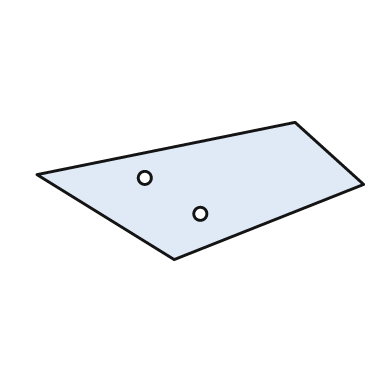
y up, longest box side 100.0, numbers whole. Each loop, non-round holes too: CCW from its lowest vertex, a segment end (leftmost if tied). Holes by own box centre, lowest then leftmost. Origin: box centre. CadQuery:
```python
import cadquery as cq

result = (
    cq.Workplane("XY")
    .moveTo(-8.0, -21.0)
    .lineTo(50.0, 2.0)
    .lineTo(29.0, 21.0)
    .lineTo(-50.0, 5.0)
    .close()
    .moveTo(0.0, -7.0)
    .circle(2.0)
    .moveTo(-17.0, 4.0)
    .circle(2.0)
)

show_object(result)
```